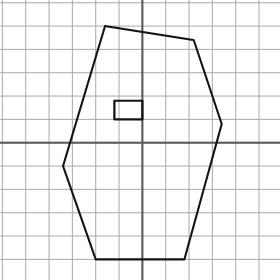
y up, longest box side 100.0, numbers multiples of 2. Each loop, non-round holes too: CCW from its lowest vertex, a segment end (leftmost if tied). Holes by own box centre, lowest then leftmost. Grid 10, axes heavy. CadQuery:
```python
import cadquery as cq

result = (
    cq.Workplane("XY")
    .moveTo(-20.0, -50.0)
    .lineTo(18.0, -50.0)
    .lineTo(34.0, 8.0)
    .lineTo(22.0, 44.0)
    .lineTo(-16.0, 50.0)
    .lineTo(-34.0, -10.0)
    .close()
    .moveTo(-12.0, 10.0)
    .lineTo(0.0, 10.0)
    .lineTo(0.0, 18.0)
    .lineTo(-12.0, 18.0)
    .close()
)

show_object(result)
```